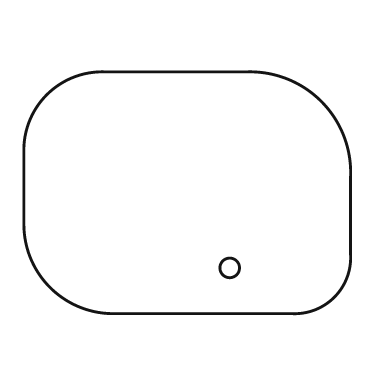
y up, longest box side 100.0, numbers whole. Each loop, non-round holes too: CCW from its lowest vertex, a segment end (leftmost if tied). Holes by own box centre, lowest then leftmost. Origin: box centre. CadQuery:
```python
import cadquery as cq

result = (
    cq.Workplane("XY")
    .moveTo(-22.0, -37.0)
    .lineTo(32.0, -37.0)
    .threePointArc((45.0, -32.0), (50.0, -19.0))
    .lineTo(50.0, 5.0)
    .threePointArc((41.0, 28.0), (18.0, 37.0))
    .lineTo(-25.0, 37.0)
    .threePointArc((-43.0, 30.0), (-50.0, 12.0))
    .lineTo(-50.0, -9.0)
    .threePointArc((-42.0, -29.0), (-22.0, -37.0))
    .close()
    .moveTo(13.0, -23.0)
    .circle(3.0)
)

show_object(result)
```